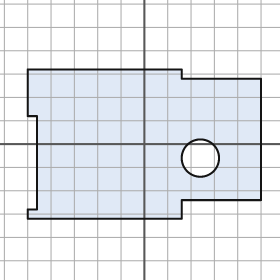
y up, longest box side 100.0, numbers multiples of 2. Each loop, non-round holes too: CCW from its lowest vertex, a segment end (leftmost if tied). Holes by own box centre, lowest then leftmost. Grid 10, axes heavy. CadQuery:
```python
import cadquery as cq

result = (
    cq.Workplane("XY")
    .moveTo(-50.0, -32.0)
    .lineTo(16.0, -32.0)
    .lineTo(16.0, -24.0)
    .lineTo(50.0, -24.0)
    .lineTo(50.0, 28.0)
    .lineTo(16.0, 28.0)
    .lineTo(16.0, 32.0)
    .lineTo(-50.0, 32.0)
    .lineTo(-50.0, 12.0)
    .lineTo(-46.0, 12.0)
    .lineTo(-46.0, -28.0)
    .lineTo(-50.0, -28.0)
    .close()
    .moveTo(24.0, -6.0)
    .circle(8.0)
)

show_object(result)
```